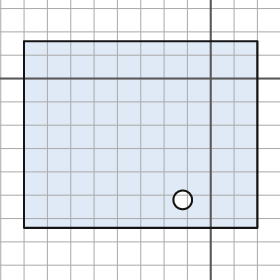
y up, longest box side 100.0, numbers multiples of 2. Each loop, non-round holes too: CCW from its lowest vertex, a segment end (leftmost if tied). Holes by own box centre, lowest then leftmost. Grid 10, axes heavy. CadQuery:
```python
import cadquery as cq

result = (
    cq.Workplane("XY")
    .moveTo(-80.0, -64.0)
    .lineTo(20.0, -64.0)
    .lineTo(20.0, 16.0)
    .lineTo(-80.0, 16.0)
    .close()
    .moveTo(-12.0, -52.0)
    .circle(4.0)
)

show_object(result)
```